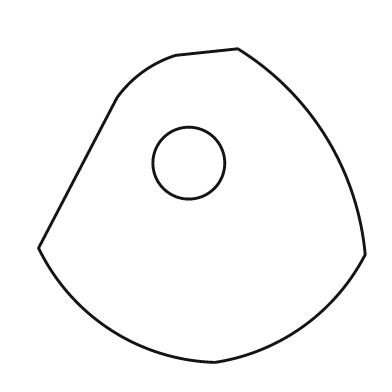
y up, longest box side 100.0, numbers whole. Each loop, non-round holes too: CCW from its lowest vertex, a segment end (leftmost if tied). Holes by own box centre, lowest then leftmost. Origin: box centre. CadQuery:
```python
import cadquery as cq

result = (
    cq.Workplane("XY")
    .moveTo(4.0, -48.0)
    .threePointArc((31.0, -37.0), (50.0, -15.0))
    .threePointArc((38.0, 21.0), (11.0, 48.0))
    .lineTo(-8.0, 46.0)
    .threePointArc((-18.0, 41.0), (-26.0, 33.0))
    .lineTo(-50.0, -13.0)
    .threePointArc((-28.0, -38.0), (4.0, -48.0))
    .close()
    .moveTo(-4.0, 13.0)
    .circle(11.0)
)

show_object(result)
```